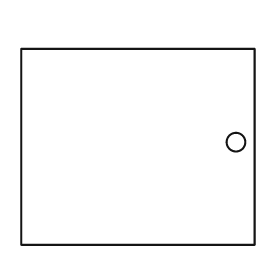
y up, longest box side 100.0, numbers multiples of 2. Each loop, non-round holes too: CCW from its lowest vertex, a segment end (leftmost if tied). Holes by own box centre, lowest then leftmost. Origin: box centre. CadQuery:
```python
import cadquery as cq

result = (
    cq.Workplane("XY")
    .moveTo(-50.0, -42.0)
    .lineTo(50.0, -42.0)
    .lineTo(50.0, 42.0)
    .lineTo(-50.0, 42.0)
    .close()
    .moveTo(42.0, 2.0)
    .circle(4.0)
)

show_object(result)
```